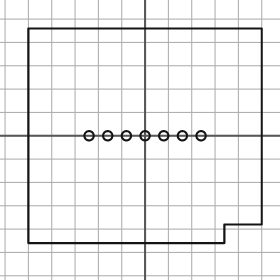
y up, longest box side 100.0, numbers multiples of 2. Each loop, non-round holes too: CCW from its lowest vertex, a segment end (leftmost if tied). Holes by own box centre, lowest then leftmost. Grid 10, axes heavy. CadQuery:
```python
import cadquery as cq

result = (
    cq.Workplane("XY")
    .moveTo(-50.0, -46.0)
    .lineTo(34.0, -46.0)
    .lineTo(34.0, -38.0)
    .lineTo(50.0, -38.0)
    .lineTo(50.0, 46.0)
    .lineTo(-50.0, 46.0)
    .close()
    .moveTo(-24.0, 0.0)
    .circle(2.0)
    .moveTo(-16.0, 0.0)
    .circle(2.0)
    .moveTo(-8.0, 0.0)
    .circle(2.0)
    .moveTo(0.0, 0.0)
    .circle(2.0)
    .moveTo(8.0, 0.0)
    .circle(2.0)
    .moveTo(16.0, 0.0)
    .circle(2.0)
    .moveTo(24.0, 0.0)
    .circle(2.0)
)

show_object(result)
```